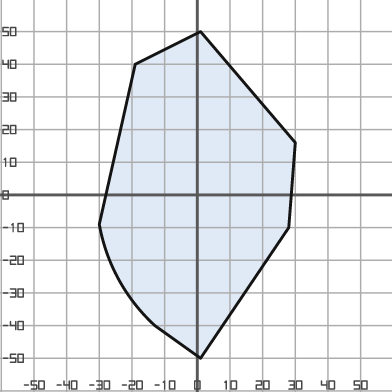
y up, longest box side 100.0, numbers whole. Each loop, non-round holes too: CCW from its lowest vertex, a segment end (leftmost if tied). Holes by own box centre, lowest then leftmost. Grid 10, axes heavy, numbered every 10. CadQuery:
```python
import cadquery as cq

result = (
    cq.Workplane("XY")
    .moveTo(1.0, -50.0)
    .lineTo(28.0, -10.0)
    .lineTo(30.0, 16.0)
    .lineTo(1.0, 50.0)
    .lineTo(-19.0, 40.0)
    .lineTo(-30.0, -9.0)
    .threePointArc((-24.0, -26.0), (-13.0, -40.0))
    .close()
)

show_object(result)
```